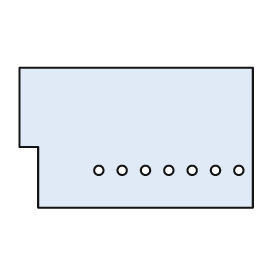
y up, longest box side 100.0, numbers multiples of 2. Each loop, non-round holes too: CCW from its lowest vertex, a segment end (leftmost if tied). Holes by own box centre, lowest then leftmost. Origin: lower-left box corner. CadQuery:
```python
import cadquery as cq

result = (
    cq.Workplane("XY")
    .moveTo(8.0, 0.0)
    .lineTo(100.0, 0.0)
    .lineTo(100.0, 60.0)
    .lineTo(0.0, 60.0)
    .lineTo(0.0, 26.0)
    .lineTo(8.0, 26.0)
    .close()
    .moveTo(34.0, 16.0)
    .circle(2.0)
    .moveTo(44.0, 16.0)
    .circle(2.0)
    .moveTo(54.0, 16.0)
    .circle(2.0)
    .moveTo(64.0, 16.0)
    .circle(2.0)
    .moveTo(74.0, 16.0)
    .circle(2.0)
    .moveTo(84.0, 16.0)
    .circle(2.0)
    .moveTo(94.0, 16.0)
    .circle(2.0)
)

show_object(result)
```